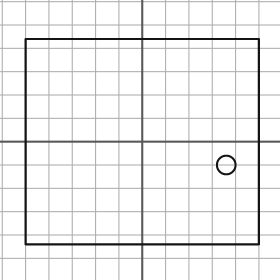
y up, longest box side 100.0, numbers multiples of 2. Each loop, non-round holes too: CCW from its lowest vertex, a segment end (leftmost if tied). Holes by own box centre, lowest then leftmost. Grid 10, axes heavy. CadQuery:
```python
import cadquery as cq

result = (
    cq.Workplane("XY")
    .moveTo(-50.0, -44.0)
    .lineTo(50.0, -44.0)
    .lineTo(50.0, 44.0)
    .lineTo(-50.0, 44.0)
    .close()
    .moveTo(36.0, -10.0)
    .circle(4.0)
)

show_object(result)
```